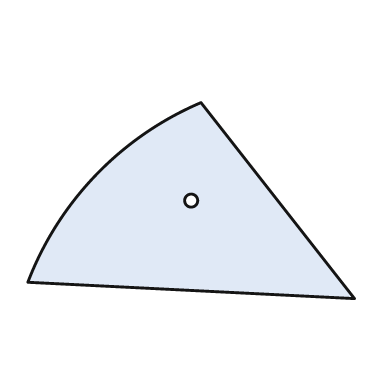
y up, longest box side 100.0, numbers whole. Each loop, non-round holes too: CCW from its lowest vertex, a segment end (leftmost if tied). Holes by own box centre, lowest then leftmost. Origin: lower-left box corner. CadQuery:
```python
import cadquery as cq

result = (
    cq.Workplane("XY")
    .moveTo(100.0, 0.0)
    .lineTo(53.0, 60.0)
    .threePointArc((21.0, 38.0), (0.0, 5.0))
    .close()
    .moveTo(50.0, 30.0)
    .circle(2.0)
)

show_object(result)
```